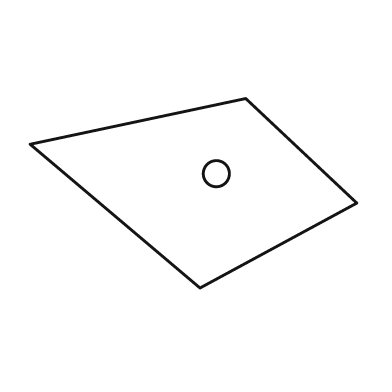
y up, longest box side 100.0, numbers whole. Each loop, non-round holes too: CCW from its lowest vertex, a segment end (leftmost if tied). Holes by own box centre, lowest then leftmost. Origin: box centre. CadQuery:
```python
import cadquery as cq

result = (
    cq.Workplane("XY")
    .moveTo(2.0, -29.0)
    .lineTo(50.0, -3.0)
    .lineTo(16.0, 29.0)
    .lineTo(-50.0, 15.0)
    .close()
    .moveTo(7.0, 6.0)
    .circle(4.0)
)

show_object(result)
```